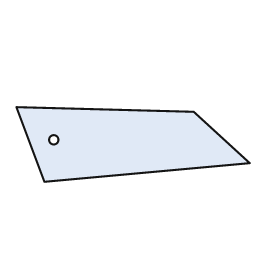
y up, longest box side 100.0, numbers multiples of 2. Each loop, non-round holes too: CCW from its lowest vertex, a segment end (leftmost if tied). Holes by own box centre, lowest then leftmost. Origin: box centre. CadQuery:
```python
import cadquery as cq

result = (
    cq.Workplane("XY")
    .moveTo(-38.0, -16.0)
    .lineTo(50.0, -8.0)
    .lineTo(26.0, 14.0)
    .lineTo(-50.0, 16.0)
    .close()
    .moveTo(-34.0, 2.0)
    .circle(2.0)
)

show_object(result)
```